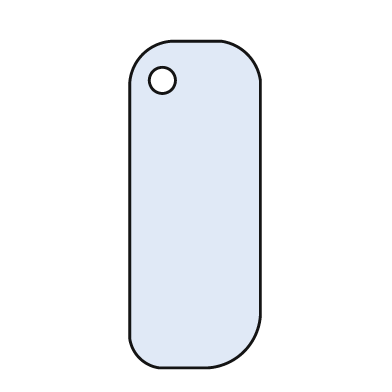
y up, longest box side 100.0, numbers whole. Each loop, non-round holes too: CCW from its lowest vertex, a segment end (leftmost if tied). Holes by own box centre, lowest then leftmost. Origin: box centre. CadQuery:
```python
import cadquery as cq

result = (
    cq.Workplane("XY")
    .moveTo(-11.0, -50.0)
    .lineTo(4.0, -50.0)
    .threePointArc((15.0, -45.0), (20.0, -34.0))
    .lineTo(20.0, 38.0)
    .threePointArc((16.0, 46.0), (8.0, 50.0))
    .lineTo(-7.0, 50.0)
    .threePointArc((-16.0, 46.0), (-20.0, 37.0))
    .lineTo(-20.0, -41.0)
    .threePointArc((-17.0, -47.0), (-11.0, -50.0))
    .close()
    .moveTo(-10.0, 38.0)
    .circle(4.0)
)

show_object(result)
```